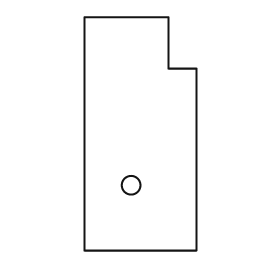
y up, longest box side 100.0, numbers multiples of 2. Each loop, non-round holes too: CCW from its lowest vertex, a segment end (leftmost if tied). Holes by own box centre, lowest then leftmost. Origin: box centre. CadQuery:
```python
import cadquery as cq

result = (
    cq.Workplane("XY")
    .moveTo(-24.0, -50.0)
    .lineTo(24.0, -50.0)
    .lineTo(24.0, 28.0)
    .lineTo(12.0, 28.0)
    .lineTo(12.0, 50.0)
    .lineTo(-24.0, 50.0)
    .close()
    .moveTo(-4.0, -22.0)
    .circle(4.0)
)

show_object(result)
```